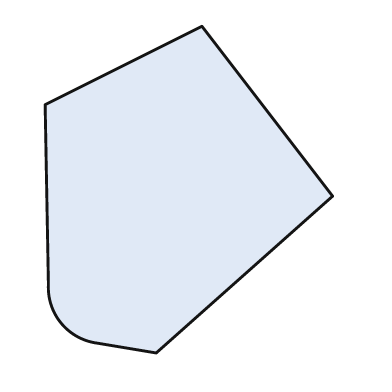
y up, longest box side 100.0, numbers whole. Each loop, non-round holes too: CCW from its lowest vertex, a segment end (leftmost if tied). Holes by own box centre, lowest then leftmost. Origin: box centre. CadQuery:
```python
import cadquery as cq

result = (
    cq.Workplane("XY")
    .moveTo(-10.0, -50.0)
    .lineTo(44.0, -2.0)
    .lineTo(4.0, 50.0)
    .lineTo(-44.0, 26.0)
    .lineTo(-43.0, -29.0)
    .threePointArc((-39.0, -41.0), (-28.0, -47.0))
    .close()
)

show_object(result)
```